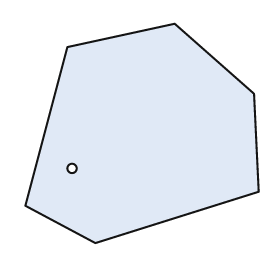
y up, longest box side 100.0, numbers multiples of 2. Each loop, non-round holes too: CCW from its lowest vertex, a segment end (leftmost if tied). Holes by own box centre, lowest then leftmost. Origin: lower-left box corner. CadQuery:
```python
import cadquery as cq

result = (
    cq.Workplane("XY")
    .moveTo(30.0, 0.0)
    .lineTo(100.0, 22.0)
    .lineTo(98.0, 64.0)
    .lineTo(64.0, 94.0)
    .lineTo(18.0, 84.0)
    .lineTo(0.0, 16.0)
    .close()
    .moveTo(20.0, 32.0)
    .circle(2.0)
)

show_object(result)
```